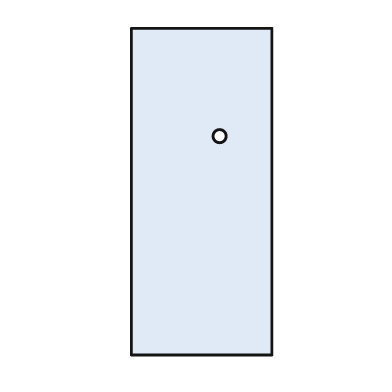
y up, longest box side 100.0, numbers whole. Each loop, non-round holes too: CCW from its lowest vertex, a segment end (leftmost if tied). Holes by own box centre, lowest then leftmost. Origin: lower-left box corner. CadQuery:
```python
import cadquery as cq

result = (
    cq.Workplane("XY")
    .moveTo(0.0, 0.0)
    .lineTo(43.0, 0.0)
    .lineTo(43.0, 100.0)
    .lineTo(0.0, 100.0)
    .close()
    .moveTo(27.0, 67.0)
    .circle(2.0)
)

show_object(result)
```